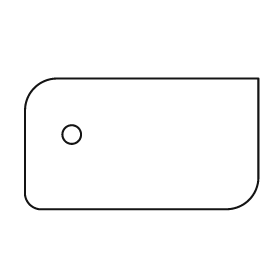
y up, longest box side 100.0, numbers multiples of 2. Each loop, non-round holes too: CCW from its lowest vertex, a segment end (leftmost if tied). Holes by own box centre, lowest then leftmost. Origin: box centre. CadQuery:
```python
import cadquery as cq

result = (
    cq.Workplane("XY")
    .moveTo(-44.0, -28.0)
    .lineTo(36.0, -28.0)
    .threePointArc((46.0, -24.0), (50.0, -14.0))
    .lineTo(50.0, 28.0)
    .lineTo(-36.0, 28.0)
    .threePointArc((-46.0, 24.0), (-50.0, 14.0))
    .lineTo(-50.0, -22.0)
    .threePointArc((-48.0, -26.0), (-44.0, -28.0))
    .close()
    .moveTo(-30.0, 4.0)
    .circle(4.0)
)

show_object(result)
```